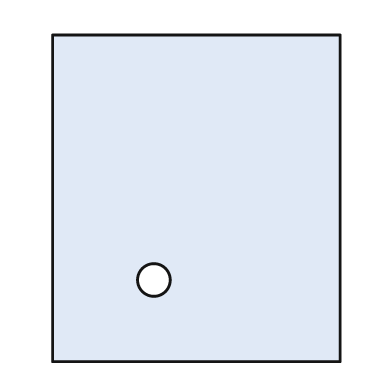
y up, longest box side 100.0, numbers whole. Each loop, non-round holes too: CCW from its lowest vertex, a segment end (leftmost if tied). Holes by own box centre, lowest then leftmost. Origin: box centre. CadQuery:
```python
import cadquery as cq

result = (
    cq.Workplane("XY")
    .moveTo(-44.0, -50.0)
    .lineTo(44.0, -50.0)
    .lineTo(44.0, 50.0)
    .lineTo(-44.0, 50.0)
    .close()
    .moveTo(-13.0, -25.0)
    .circle(5.0)
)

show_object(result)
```